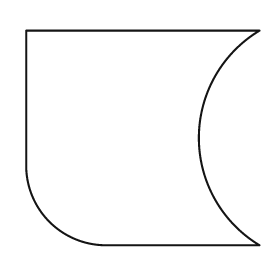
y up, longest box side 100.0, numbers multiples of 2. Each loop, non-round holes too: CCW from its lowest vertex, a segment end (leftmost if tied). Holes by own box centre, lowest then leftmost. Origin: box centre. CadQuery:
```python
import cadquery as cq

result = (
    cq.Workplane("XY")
    .moveTo(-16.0, -46.0)
    .lineTo(50.0, -46.0)
    .threePointArc((24.0, 0.0), (50.0, 46.0))
    .lineTo(-50.0, 46.0)
    .lineTo(-50.0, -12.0)
    .threePointArc((-40.0, -36.0), (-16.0, -46.0))
    .close()
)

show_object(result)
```